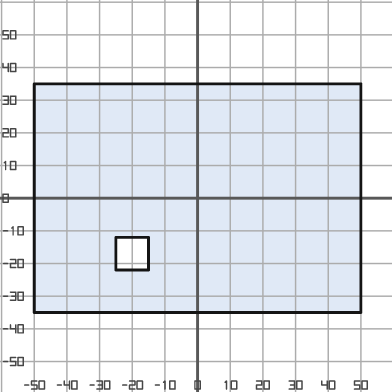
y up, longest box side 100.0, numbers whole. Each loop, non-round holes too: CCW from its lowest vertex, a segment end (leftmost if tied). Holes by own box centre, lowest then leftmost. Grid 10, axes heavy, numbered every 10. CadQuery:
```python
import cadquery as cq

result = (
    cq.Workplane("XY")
    .moveTo(-50.0, -35.0)
    .lineTo(50.0, -35.0)
    .lineTo(50.0, 35.0)
    .lineTo(-50.0, 35.0)
    .close()
    .moveTo(-25.0, -22.0)
    .lineTo(-15.0, -22.0)
    .lineTo(-15.0, -12.0)
    .lineTo(-25.0, -12.0)
    .close()
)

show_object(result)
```